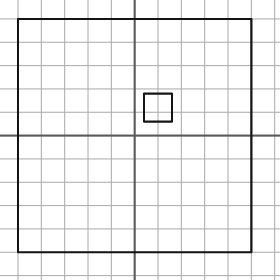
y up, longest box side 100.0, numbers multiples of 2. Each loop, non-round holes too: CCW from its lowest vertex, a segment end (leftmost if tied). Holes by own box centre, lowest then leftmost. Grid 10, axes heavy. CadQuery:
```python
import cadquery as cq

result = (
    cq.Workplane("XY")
    .moveTo(-50.0, -50.0)
    .lineTo(50.0, -50.0)
    .lineTo(50.0, 50.0)
    .lineTo(-50.0, 50.0)
    .close()
    .moveTo(4.0, 6.0)
    .lineTo(16.0, 6.0)
    .lineTo(16.0, 18.0)
    .lineTo(4.0, 18.0)
    .close()
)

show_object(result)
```